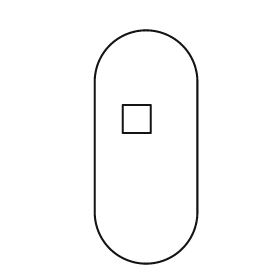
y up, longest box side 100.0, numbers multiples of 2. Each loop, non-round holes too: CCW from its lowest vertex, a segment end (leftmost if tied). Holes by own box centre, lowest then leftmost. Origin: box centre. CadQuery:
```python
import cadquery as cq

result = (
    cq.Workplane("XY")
    .moveTo(-22.0, -28.0)
    .threePointArc((0.0, -50.0), (22.0, -28.0))
    .lineTo(22.0, 28.0)
    .threePointArc((0.0, 50.0), (-22.0, 28.0))
    .close()
    .moveTo(-10.0, 6.0)
    .lineTo(2.0, 6.0)
    .lineTo(2.0, 18.0)
    .lineTo(-10.0, 18.0)
    .close()
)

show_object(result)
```